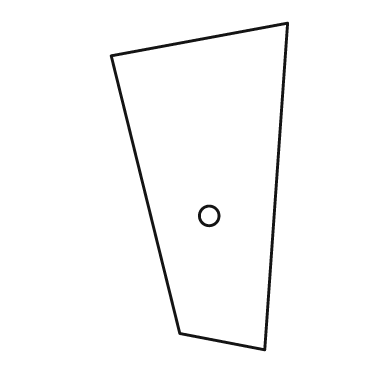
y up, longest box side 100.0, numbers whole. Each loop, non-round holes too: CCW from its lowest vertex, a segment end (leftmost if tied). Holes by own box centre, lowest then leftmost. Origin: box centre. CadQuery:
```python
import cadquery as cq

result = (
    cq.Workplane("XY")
    .moveTo(20.0, -50.0)
    .lineTo(27.0, 50.0)
    .lineTo(-27.0, 40.0)
    .lineTo(-6.0, -45.0)
    .close()
    .moveTo(3.0, -9.0)
    .circle(3.0)
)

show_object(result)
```